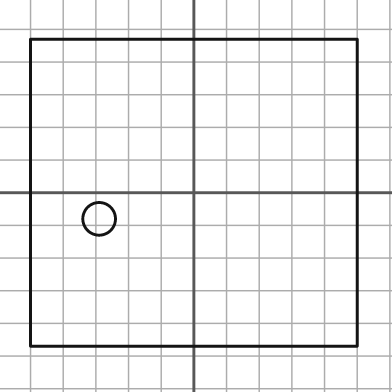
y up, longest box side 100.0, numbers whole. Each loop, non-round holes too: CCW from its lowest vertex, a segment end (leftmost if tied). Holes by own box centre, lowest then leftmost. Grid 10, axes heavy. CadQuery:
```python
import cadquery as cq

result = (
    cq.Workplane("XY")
    .moveTo(-50.0, -47.0)
    .lineTo(50.0, -47.0)
    .lineTo(50.0, 47.0)
    .lineTo(-50.0, 47.0)
    .close()
    .moveTo(-29.0, -8.0)
    .circle(5.0)
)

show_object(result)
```